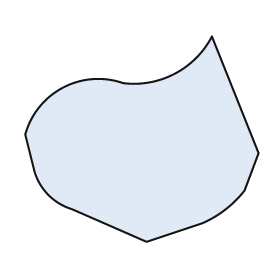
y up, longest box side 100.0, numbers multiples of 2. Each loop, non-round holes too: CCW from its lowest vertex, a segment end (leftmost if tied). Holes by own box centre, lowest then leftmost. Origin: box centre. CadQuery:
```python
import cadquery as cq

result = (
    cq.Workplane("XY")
    .moveTo(2.0, -44.0)
    .lineTo(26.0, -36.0)
    .threePointArc((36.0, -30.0), (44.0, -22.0))
    .lineTo(50.0, -6.0)
    .lineTo(30.0, 44.0)
    .threePointArc((14.0, 28.0), (-8.0, 24.0))
    .threePointArc((-34.0, 22.0), (-50.0, 2.0))
    .lineTo(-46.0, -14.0)
    .threePointArc((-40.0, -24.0), (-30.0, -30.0))
    .close()
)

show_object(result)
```